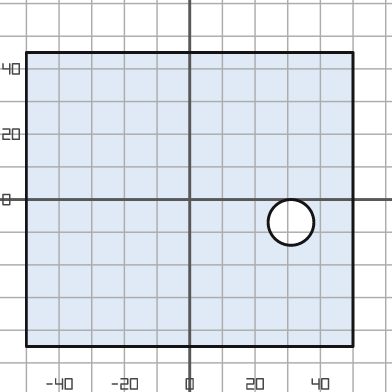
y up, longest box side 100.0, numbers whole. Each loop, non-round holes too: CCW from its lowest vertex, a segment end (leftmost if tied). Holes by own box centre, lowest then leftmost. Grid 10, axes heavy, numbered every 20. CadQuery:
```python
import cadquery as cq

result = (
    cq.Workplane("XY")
    .moveTo(-50.0, -45.0)
    .lineTo(50.0, -45.0)
    .lineTo(50.0, 45.0)
    .lineTo(-50.0, 45.0)
    .close()
    .moveTo(31.0, -7.0)
    .circle(7.0)
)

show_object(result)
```